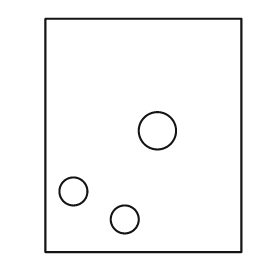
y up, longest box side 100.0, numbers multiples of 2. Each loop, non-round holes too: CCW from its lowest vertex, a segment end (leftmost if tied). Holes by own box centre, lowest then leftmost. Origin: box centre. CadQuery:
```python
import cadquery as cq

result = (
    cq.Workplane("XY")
    .moveTo(-42.0, -50.0)
    .lineTo(42.0, -50.0)
    .lineTo(42.0, 50.0)
    .lineTo(-42.0, 50.0)
    .close()
    .moveTo(-8.0, -36.0)
    .circle(6.0)
    .moveTo(-30.0, -24.0)
    .circle(6.0)
    .moveTo(6.0, 2.0)
    .circle(8.0)
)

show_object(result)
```